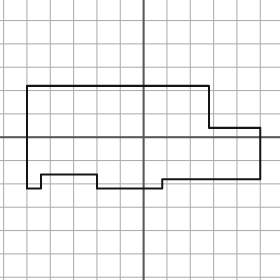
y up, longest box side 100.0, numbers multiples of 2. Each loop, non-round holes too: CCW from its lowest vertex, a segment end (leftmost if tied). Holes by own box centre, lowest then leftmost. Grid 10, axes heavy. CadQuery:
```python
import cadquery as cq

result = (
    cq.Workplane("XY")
    .moveTo(-50.0, -22.0)
    .lineTo(-44.0, -22.0)
    .lineTo(-44.0, -16.0)
    .lineTo(-20.0, -16.0)
    .lineTo(-20.0, -22.0)
    .lineTo(8.0, -22.0)
    .lineTo(8.0, -18.0)
    .lineTo(50.0, -18.0)
    .lineTo(50.0, 4.0)
    .lineTo(28.0, 4.0)
    .lineTo(28.0, 22.0)
    .lineTo(-50.0, 22.0)
    .close()
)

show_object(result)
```